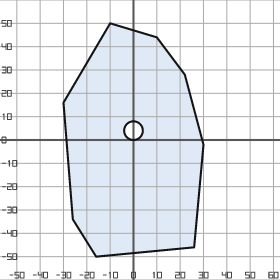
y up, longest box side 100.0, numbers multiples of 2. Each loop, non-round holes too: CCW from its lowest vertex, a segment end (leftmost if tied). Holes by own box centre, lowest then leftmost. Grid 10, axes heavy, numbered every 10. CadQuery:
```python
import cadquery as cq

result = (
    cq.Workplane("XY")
    .moveTo(-16.0, -50.0)
    .lineTo(26.0, -46.0)
    .lineTo(30.0, -2.0)
    .lineTo(22.0, 28.0)
    .lineTo(10.0, 44.0)
    .lineTo(-10.0, 50.0)
    .lineTo(-30.0, 16.0)
    .lineTo(-26.0, -34.0)
    .close()
    .moveTo(0.0, 4.0)
    .circle(4.0)
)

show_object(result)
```